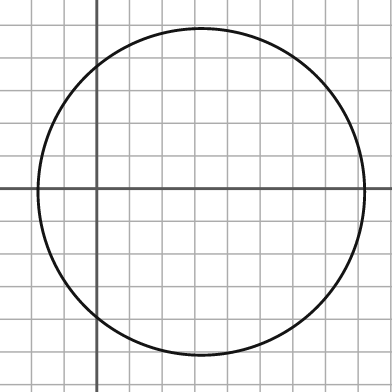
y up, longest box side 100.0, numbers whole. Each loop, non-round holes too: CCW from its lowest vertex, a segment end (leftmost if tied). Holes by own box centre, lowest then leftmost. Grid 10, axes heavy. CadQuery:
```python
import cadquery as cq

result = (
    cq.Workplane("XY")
    .moveTo(32.0, -1.0)
    .circle(50.0)
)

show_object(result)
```